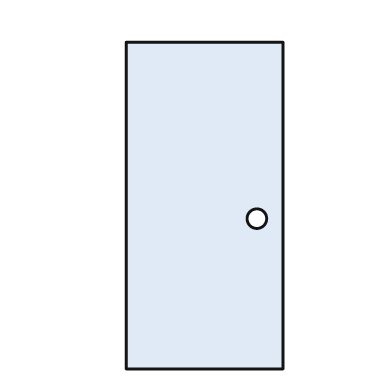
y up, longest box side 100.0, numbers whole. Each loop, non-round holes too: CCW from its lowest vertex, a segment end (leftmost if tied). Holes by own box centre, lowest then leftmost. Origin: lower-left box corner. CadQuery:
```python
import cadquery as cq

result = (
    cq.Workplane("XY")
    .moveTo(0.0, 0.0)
    .lineTo(48.0, 0.0)
    .lineTo(48.0, 100.0)
    .lineTo(0.0, 100.0)
    .close()
    .moveTo(40.0, 46.0)
    .circle(3.0)
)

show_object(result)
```